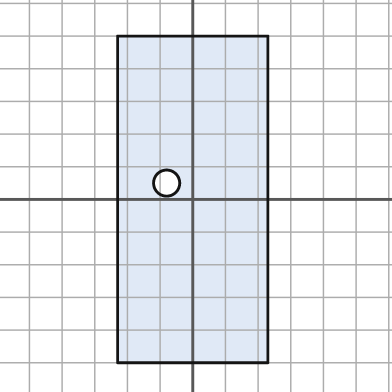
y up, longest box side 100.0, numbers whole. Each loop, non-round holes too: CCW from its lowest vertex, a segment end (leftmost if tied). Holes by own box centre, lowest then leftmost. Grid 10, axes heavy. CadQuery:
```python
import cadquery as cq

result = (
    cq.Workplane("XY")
    .moveTo(-23.0, -50.0)
    .lineTo(23.0, -50.0)
    .lineTo(23.0, 50.0)
    .lineTo(-23.0, 50.0)
    .close()
    .moveTo(-8.0, 5.0)
    .circle(4.0)
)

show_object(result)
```